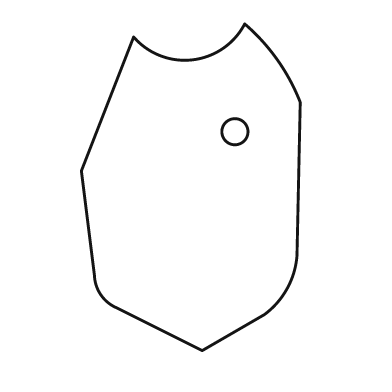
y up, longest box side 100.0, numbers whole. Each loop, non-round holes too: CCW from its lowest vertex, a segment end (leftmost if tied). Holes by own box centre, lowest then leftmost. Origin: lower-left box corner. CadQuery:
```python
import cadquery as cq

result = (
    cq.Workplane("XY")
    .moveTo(37.0, 0.0)
    .lineTo(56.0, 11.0)
    .threePointArc((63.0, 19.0), (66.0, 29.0))
    .lineTo(67.0, 76.0)
    .threePointArc((60.0, 89.0), (50.0, 100.0))
    .threePointArc((34.0, 89.0), (16.0, 96.0))
    .lineTo(0.0, 55.0)
    .lineTo(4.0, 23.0)
    .threePointArc((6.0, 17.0), (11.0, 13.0))
    .close()
    .moveTo(47.0, 67.0)
    .circle(4.0)
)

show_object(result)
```